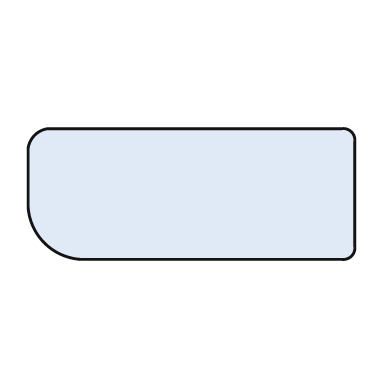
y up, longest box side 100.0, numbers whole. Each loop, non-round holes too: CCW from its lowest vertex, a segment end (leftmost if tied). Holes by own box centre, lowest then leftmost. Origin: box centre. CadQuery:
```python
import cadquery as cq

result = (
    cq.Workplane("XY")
    .moveTo(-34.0, -20.0)
    .lineTo(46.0, -20.0)
    .threePointArc((49.0, -19.0), (50.0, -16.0))
    .lineTo(50.0, 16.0)
    .threePointArc((49.0, 19.0), (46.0, 20.0))
    .lineTo(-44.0, 20.0)
    .threePointArc((-48.0, 18.0), (-50.0, 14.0))
    .lineTo(-50.0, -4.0)
    .threePointArc((-45.0, -15.0), (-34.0, -20.0))
    .close()
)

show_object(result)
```